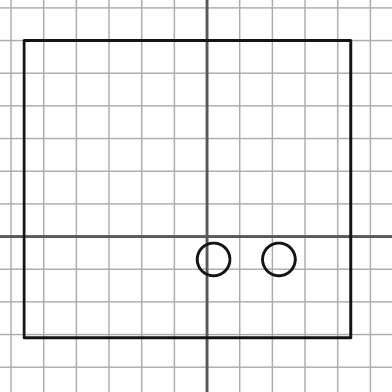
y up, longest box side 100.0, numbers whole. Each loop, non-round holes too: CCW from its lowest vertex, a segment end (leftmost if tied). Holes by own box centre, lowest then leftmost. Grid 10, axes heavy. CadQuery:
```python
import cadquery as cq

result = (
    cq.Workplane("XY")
    .moveTo(-56.0, -31.0)
    .lineTo(44.0, -31.0)
    .lineTo(44.0, 60.0)
    .lineTo(-56.0, 60.0)
    .close()
    .moveTo(2.0, -7.0)
    .circle(5.0)
    .moveTo(22.0, -7.0)
    .circle(5.0)
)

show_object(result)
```